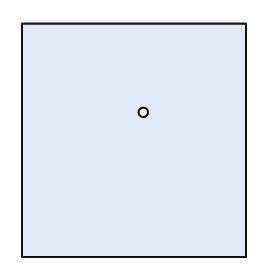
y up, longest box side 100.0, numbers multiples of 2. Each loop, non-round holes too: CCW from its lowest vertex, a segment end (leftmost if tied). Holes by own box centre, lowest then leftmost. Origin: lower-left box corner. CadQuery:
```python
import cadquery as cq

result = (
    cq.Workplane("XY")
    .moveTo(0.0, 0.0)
    .lineTo(96.0, 0.0)
    .lineTo(96.0, 100.0)
    .lineTo(0.0, 100.0)
    .close()
    .moveTo(52.0, 62.0)
    .circle(2.0)
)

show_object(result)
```